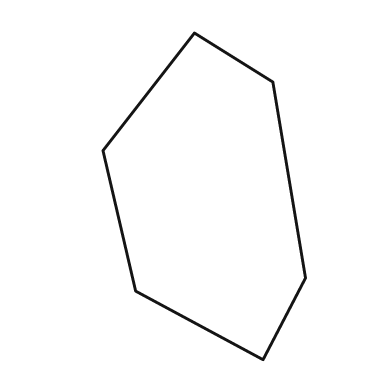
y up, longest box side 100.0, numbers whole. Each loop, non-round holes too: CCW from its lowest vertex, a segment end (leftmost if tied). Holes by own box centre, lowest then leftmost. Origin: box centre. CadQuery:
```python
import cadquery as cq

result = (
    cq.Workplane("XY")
    .moveTo(18.0, -50.0)
    .lineTo(31.0, -25.0)
    .lineTo(21.0, 35.0)
    .lineTo(-3.0, 50.0)
    .lineTo(-31.0, 14.0)
    .lineTo(-21.0, -29.0)
    .close()
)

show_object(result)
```